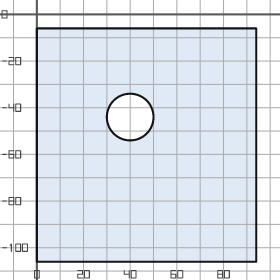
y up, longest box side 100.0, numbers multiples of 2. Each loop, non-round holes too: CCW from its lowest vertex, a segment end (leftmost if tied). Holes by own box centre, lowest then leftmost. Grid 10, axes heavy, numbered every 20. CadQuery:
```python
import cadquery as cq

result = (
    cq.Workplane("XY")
    .moveTo(0.0, -106.0)
    .lineTo(94.0, -106.0)
    .lineTo(94.0, -6.0)
    .lineTo(0.0, -6.0)
    .close()
    .moveTo(40.0, -44.0)
    .circle(10.0)
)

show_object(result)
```